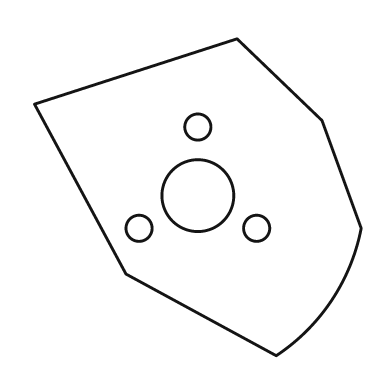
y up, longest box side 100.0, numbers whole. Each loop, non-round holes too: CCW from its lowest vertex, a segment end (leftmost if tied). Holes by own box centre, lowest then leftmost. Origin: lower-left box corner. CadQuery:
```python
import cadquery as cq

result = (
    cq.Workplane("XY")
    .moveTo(74.0, 0.0)
    .threePointArc((91.0, 17.0), (100.0, 39.0))
    .lineTo(88.0, 72.0)
    .lineTo(62.0, 97.0)
    .lineTo(0.0, 77.0)
    .lineTo(28.0, 25.0)
    .close()
    .moveTo(32.0, 39.0)
    .circle(4.0)
    .moveTo(68.0, 39.0)
    .circle(4.0)
    .moveTo(50.0, 49.0)
    .circle(11.0)
    .moveTo(50.0, 70.0)
    .circle(4.0)
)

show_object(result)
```